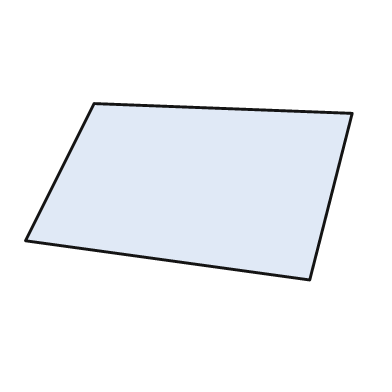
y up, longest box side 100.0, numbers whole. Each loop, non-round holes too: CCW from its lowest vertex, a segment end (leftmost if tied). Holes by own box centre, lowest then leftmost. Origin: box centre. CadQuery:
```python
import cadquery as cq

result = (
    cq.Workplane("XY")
    .moveTo(37.0, -27.0)
    .lineTo(50.0, 24.0)
    .lineTo(-29.0, 27.0)
    .lineTo(-50.0, -15.0)
    .close()
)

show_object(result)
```